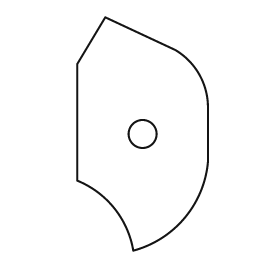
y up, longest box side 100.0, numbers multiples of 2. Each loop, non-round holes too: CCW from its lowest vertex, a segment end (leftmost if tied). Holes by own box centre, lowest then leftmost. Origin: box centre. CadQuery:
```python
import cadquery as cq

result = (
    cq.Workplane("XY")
    .moveTo(-4.0, -50.0)
    .threePointArc((18.0, -36.0), (28.0, -12.0))
    .lineTo(28.0, 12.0)
    .threePointArc((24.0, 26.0), (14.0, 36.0))
    .lineTo(-16.0, 50.0)
    .lineTo(-28.0, 30.0)
    .lineTo(-28.0, -20.0)
    .threePointArc((-12.0, -32.0), (-4.0, -50.0))
    .close()
    .moveTo(0.0, 0.0)
    .circle(6.0)
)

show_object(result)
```